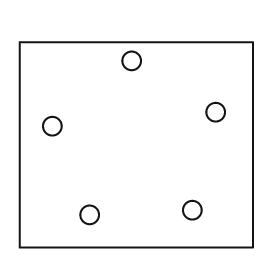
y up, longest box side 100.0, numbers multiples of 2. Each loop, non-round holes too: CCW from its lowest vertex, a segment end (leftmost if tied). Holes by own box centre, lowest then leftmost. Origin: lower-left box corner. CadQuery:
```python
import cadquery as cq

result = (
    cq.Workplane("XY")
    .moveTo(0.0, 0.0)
    .lineTo(100.0, 0.0)
    .lineTo(100.0, 88.0)
    .lineTo(0.0, 88.0)
    .close()
    .moveTo(30.0, 14.0)
    .circle(4.0)
    .moveTo(74.0, 16.0)
    .circle(4.0)
    .moveTo(14.0, 52.0)
    .circle(4.0)
    .moveTo(84.0, 58.0)
    .circle(4.0)
    .moveTo(48.0, 80.0)
    .circle(4.0)
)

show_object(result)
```